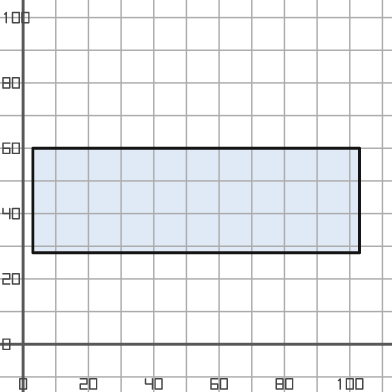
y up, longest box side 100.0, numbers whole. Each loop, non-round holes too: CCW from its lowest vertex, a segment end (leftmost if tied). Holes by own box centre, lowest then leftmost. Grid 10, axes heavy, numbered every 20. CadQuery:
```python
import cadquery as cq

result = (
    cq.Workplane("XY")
    .moveTo(3.0, 28.0)
    .lineTo(103.0, 28.0)
    .lineTo(103.0, 60.0)
    .lineTo(3.0, 60.0)
    .close()
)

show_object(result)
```